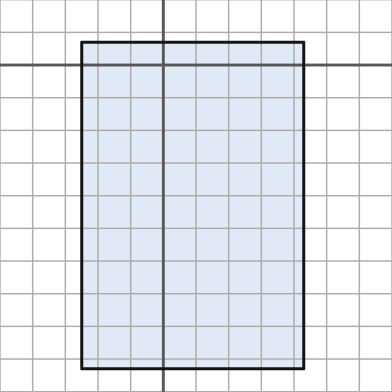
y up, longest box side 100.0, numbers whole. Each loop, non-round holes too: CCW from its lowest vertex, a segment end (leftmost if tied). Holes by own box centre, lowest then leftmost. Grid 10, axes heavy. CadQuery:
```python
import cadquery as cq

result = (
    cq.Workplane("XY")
    .moveTo(-25.0, -93.0)
    .lineTo(43.0, -93.0)
    .lineTo(43.0, 7.0)
    .lineTo(-25.0, 7.0)
    .close()
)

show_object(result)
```